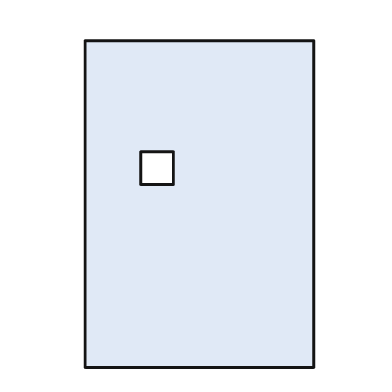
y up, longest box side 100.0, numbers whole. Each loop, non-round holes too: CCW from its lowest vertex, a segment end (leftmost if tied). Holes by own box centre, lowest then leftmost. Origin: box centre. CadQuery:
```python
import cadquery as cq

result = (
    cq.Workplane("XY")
    .moveTo(-35.0, -50.0)
    .lineTo(35.0, -50.0)
    .lineTo(35.0, 50.0)
    .lineTo(-35.0, 50.0)
    .close()
    .moveTo(-18.0, 6.0)
    .lineTo(-8.0, 6.0)
    .lineTo(-8.0, 16.0)
    .lineTo(-18.0, 16.0)
    .close()
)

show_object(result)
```